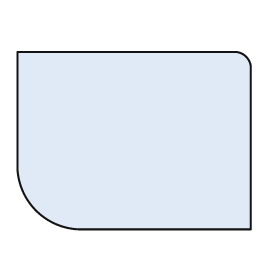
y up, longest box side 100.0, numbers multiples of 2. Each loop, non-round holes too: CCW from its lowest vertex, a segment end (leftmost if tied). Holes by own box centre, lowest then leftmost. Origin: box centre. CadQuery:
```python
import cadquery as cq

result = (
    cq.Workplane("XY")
    .moveTo(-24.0, -38.0)
    .lineTo(50.0, -38.0)
    .lineTo(50.0, 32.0)
    .threePointArc((48.0, 36.0), (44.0, 38.0))
    .lineTo(-50.0, 38.0)
    .lineTo(-50.0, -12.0)
    .threePointArc((-42.0, -30.0), (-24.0, -38.0))
    .close()
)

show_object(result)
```